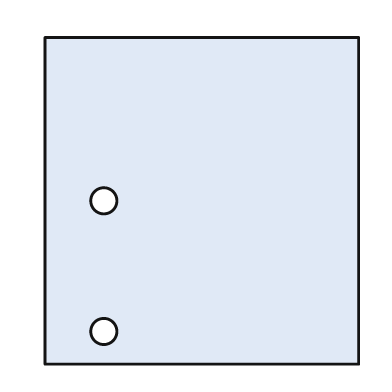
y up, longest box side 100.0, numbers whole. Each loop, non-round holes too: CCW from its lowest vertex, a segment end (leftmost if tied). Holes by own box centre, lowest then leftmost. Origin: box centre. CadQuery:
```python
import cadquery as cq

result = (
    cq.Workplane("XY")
    .moveTo(-48.0, -50.0)
    .lineTo(48.0, -50.0)
    .lineTo(48.0, 50.0)
    .lineTo(-48.0, 50.0)
    .close()
    .moveTo(-30.0, -40.0)
    .circle(4.0)
    .moveTo(-30.0, 0.0)
    .circle(4.0)
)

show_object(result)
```